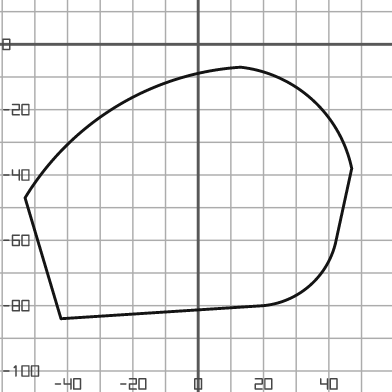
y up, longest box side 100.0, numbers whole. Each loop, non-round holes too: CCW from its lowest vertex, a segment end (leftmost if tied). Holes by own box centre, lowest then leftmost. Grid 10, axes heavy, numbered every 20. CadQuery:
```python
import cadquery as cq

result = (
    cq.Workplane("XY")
    .moveTo(-42.0, -84.0)
    .lineTo(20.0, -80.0)
    .threePointArc((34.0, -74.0), (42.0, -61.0))
    .lineTo(47.0, -38.0)
    .threePointArc((35.0, -17.0), (13.0, -7.0))
    .threePointArc((-25.0, -19.0), (-53.0, -47.0))
    .close()
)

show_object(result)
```